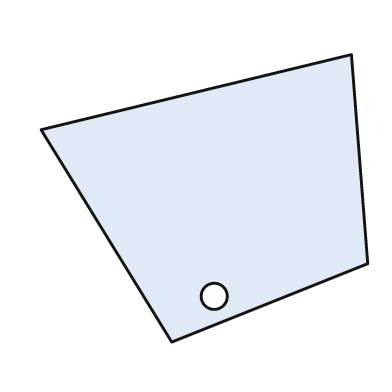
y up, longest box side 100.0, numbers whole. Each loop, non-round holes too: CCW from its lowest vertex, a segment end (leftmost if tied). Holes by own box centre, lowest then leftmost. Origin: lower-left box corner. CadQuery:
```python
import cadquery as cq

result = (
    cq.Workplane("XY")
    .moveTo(40.0, 0.0)
    .lineTo(100.0, 24.0)
    .lineTo(95.0, 88.0)
    .lineTo(0.0, 65.0)
    .close()
    .moveTo(53.0, 14.0)
    .circle(4.0)
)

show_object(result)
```